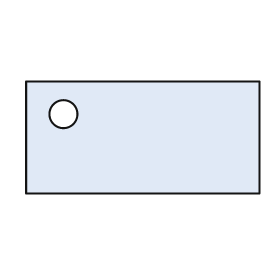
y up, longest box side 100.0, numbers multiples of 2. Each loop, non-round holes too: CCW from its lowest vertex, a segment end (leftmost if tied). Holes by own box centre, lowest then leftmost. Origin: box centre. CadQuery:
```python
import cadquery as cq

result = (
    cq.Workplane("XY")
    .moveTo(-50.0, -24.0)
    .lineTo(50.0, -24.0)
    .lineTo(50.0, 24.0)
    .lineTo(-50.0, 24.0)
    .close()
    .moveTo(-34.0, 10.0)
    .circle(6.0)
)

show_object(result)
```